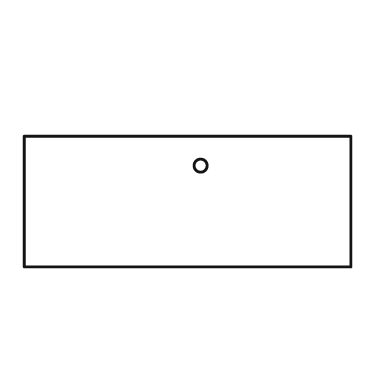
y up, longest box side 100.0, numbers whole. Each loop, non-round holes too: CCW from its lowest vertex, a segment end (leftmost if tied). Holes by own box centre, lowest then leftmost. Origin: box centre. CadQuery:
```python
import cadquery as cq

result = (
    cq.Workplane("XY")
    .moveTo(-50.0, -20.0)
    .lineTo(50.0, -20.0)
    .lineTo(50.0, 20.0)
    .lineTo(-50.0, 20.0)
    .close()
    .moveTo(4.0, 11.0)
    .circle(2.0)
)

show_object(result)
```